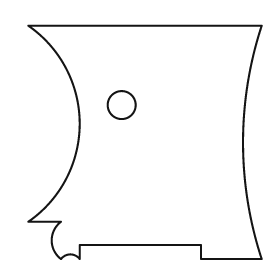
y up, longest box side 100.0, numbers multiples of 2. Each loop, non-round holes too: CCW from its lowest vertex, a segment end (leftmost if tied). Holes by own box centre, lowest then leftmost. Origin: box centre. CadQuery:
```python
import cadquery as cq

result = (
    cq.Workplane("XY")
    .moveTo(-36.0, -50.0)
    .threePointArc((-32.0, -48.0), (-28.0, -50.0))
    .lineTo(-28.0, -44.0)
    .lineTo(24.0, -44.0)
    .lineTo(24.0, -50.0)
    .lineTo(50.0, -50.0)
    .threePointArc((42.0, 0.0), (50.0, 50.0))
    .lineTo(-50.0, 50.0)
    .threePointArc((-28.0, 8.0), (-50.0, -34.0))
    .lineTo(-36.0, -34.0)
    .threePointArc((-40.0, -42.0), (-36.0, -50.0))
    .close()
    .moveTo(-10.0, 16.0)
    .circle(6.0)
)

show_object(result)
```